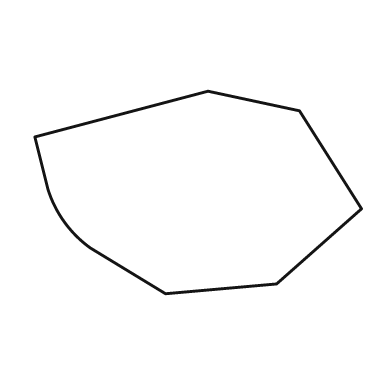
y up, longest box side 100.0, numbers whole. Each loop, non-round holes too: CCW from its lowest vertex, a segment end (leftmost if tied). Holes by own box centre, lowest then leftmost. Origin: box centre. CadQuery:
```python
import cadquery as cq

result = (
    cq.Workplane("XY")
    .moveTo(-10.0, -31.0)
    .lineTo(24.0, -28.0)
    .lineTo(50.0, -5.0)
    .lineTo(31.0, 25.0)
    .lineTo(3.0, 31.0)
    .lineTo(-50.0, 17.0)
    .lineTo(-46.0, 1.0)
    .threePointArc((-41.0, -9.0), (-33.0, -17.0))
    .close()
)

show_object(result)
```